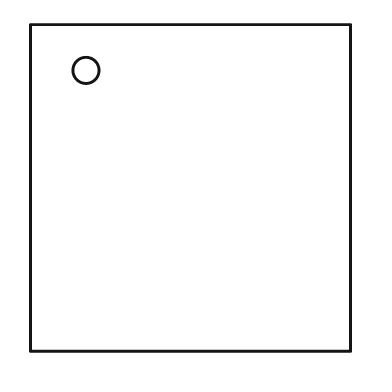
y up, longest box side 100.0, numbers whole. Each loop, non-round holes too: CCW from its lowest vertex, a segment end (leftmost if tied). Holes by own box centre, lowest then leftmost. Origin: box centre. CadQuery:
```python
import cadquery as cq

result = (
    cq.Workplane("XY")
    .moveTo(-49.0, -50.0)
    .lineTo(49.0, -50.0)
    .lineTo(49.0, 50.0)
    .lineTo(-49.0, 50.0)
    .close()
    .moveTo(-32.0, 36.0)
    .circle(4.0)
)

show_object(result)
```